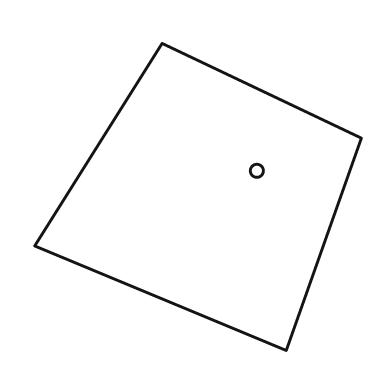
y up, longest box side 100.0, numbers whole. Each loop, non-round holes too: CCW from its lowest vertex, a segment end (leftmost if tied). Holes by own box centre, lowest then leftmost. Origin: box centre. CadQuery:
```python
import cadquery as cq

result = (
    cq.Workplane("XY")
    .moveTo(27.0, -47.0)
    .lineTo(50.0, 18.0)
    .lineTo(-11.0, 47.0)
    .lineTo(-50.0, -15.0)
    .close()
    .moveTo(18.0, 8.0)
    .circle(2.0)
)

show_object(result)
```